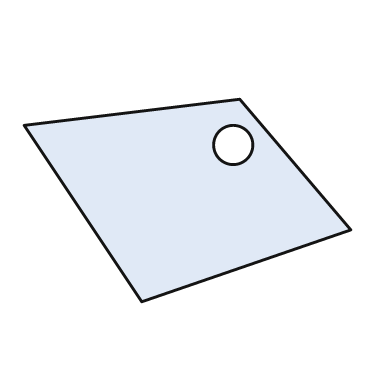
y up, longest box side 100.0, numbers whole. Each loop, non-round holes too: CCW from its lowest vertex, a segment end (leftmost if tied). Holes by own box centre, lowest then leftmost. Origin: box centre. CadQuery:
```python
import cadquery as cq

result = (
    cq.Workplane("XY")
    .moveTo(-14.0, -31.0)
    .lineTo(50.0, -9.0)
    .lineTo(16.0, 31.0)
    .lineTo(-50.0, 23.0)
    .close()
    .moveTo(14.0, 17.0)
    .circle(6.0)
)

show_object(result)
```